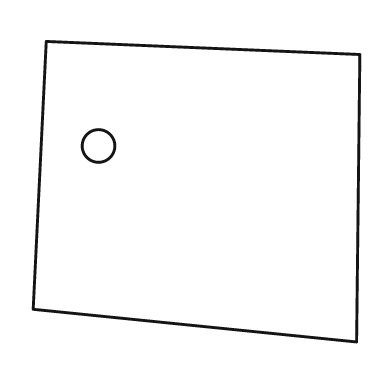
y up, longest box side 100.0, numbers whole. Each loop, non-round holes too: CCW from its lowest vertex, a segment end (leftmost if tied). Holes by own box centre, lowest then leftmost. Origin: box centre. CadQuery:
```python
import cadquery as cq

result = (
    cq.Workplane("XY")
    .moveTo(49.0, -46.0)
    .lineTo(50.0, 42.0)
    .lineTo(-46.0, 46.0)
    .lineTo(-50.0, -36.0)
    .close()
    .moveTo(-30.0, 14.0)
    .circle(5.0)
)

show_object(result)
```